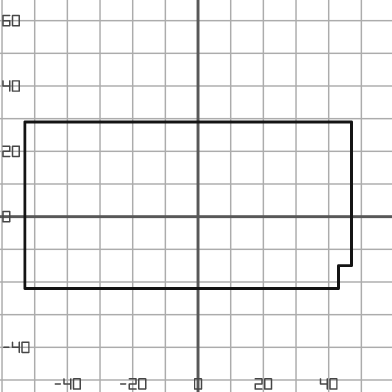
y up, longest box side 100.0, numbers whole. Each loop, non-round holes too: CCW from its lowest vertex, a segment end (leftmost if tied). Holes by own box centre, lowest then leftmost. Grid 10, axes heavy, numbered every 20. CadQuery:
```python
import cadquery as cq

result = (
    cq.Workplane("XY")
    .moveTo(-53.0, -22.0)
    .lineTo(43.0, -22.0)
    .lineTo(43.0, -15.0)
    .lineTo(47.0, -15.0)
    .lineTo(47.0, 29.0)
    .lineTo(-53.0, 29.0)
    .close()
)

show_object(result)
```